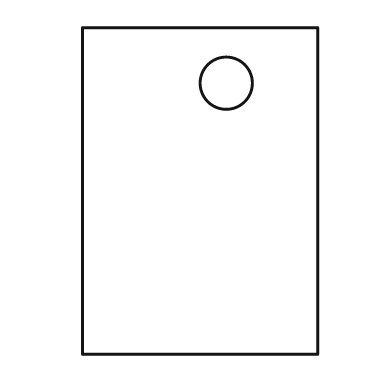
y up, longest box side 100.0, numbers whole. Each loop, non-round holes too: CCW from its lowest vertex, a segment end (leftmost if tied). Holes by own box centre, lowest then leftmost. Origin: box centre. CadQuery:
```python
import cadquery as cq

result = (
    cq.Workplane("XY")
    .moveTo(-36.0, -50.0)
    .lineTo(36.0, -50.0)
    .lineTo(36.0, 50.0)
    .lineTo(-36.0, 50.0)
    .close()
    .moveTo(8.0, 33.0)
    .circle(8.0)
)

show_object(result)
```